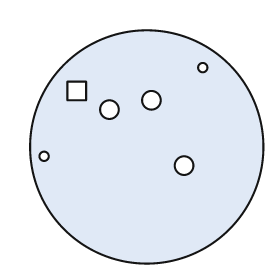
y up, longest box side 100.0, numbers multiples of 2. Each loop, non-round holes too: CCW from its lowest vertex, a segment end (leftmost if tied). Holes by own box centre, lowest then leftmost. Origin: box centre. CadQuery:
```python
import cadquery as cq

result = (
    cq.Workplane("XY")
    .moveTo(0.0, 0.0)
    .circle(50.0)
    .moveTo(16.0, -8.0)
    .circle(4.0)
    .moveTo(-44.0, -4.0)
    .circle(2.0)
    .moveTo(-16.0, 16.0)
    .circle(4.0)
    .moveTo(2.0, 20.0)
    .circle(4.0)
    .moveTo(-34.0, 20.0)
    .lineTo(-26.0, 20.0)
    .lineTo(-26.0, 28.0)
    .lineTo(-34.0, 28.0)
    .close()
    .moveTo(24.0, 34.0)
    .circle(2.0)
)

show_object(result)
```